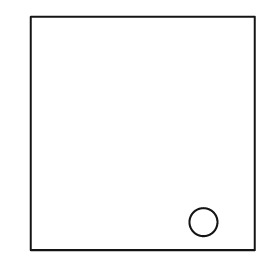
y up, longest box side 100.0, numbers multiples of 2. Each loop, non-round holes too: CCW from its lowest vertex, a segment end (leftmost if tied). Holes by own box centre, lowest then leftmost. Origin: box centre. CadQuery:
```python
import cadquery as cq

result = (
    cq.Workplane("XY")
    .moveTo(-48.0, -50.0)
    .lineTo(48.0, -50.0)
    .lineTo(48.0, 50.0)
    .lineTo(-48.0, 50.0)
    .close()
    .moveTo(26.0, -38.0)
    .circle(6.0)
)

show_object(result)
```